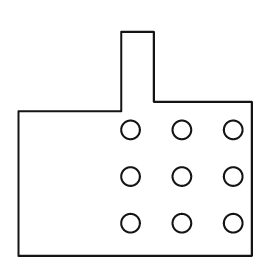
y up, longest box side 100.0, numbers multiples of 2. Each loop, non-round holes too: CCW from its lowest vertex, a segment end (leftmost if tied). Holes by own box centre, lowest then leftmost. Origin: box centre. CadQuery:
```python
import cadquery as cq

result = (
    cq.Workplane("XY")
    .moveTo(-50.0, -48.0)
    .lineTo(50.0, -48.0)
    .lineTo(50.0, 18.0)
    .lineTo(8.0, 18.0)
    .lineTo(8.0, 48.0)
    .lineTo(-6.0, 48.0)
    .lineTo(-6.0, 14.0)
    .lineTo(-50.0, 14.0)
    .close()
    .moveTo(-2.0, -34.0)
    .circle(4.0)
    .moveTo(20.0, -34.0)
    .circle(4.0)
    .moveTo(42.0, -34.0)
    .circle(4.0)
    .moveTo(-2.0, -14.0)
    .circle(4.0)
    .moveTo(20.0, -14.0)
    .circle(4.0)
    .moveTo(42.0, -14.0)
    .circle(4.0)
    .moveTo(-2.0, 6.0)
    .circle(4.0)
    .moveTo(20.0, 6.0)
    .circle(4.0)
    .moveTo(42.0, 6.0)
    .circle(4.0)
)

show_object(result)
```